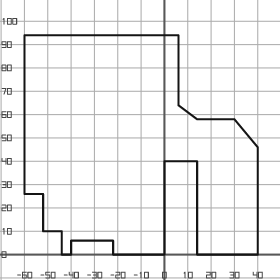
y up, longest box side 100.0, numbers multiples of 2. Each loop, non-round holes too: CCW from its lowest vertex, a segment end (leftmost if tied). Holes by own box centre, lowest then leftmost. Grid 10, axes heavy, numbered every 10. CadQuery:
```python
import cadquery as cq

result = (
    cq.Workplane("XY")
    .moveTo(-44.0, 0.0)
    .lineTo(-40.0, 0.0)
    .lineTo(-40.0, 6.0)
    .lineTo(-22.0, 6.0)
    .lineTo(-22.0, 0.0)
    .lineTo(0.0, 0.0)
    .lineTo(0.0, 40.0)
    .lineTo(14.0, 40.0)
    .lineTo(14.0, 0.0)
    .lineTo(40.0, 0.0)
    .lineTo(40.0, 46.0)
    .lineTo(30.0, 58.0)
    .lineTo(14.0, 58.0)
    .lineTo(6.0, 64.0)
    .lineTo(6.0, 94.0)
    .lineTo(-60.0, 94.0)
    .lineTo(-60.0, 26.0)
    .lineTo(-52.0, 26.0)
    .lineTo(-52.0, 10.0)
    .lineTo(-44.0, 10.0)
    .close()
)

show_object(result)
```